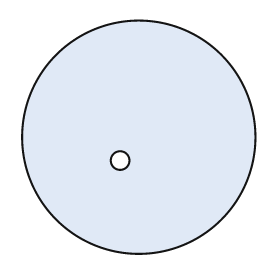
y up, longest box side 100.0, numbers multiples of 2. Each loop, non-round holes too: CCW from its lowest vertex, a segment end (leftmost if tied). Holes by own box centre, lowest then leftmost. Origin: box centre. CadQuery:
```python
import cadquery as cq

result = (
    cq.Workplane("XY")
    .moveTo(0.0, 0.0)
    .circle(50.0)
    .moveTo(-8.0, -10.0)
    .circle(4.0)
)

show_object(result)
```